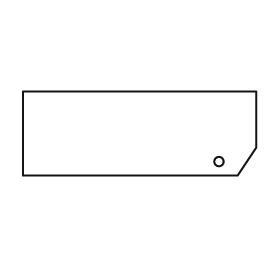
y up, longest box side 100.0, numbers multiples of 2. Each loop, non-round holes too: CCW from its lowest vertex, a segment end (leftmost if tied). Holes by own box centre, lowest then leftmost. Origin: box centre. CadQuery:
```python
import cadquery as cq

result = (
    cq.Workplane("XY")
    .moveTo(-50.0, -18.0)
    .lineTo(42.0, -18.0)
    .lineTo(50.0, -6.0)
    .lineTo(50.0, 18.0)
    .lineTo(-50.0, 18.0)
    .close()
    .moveTo(34.0, -12.0)
    .circle(2.0)
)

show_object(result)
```